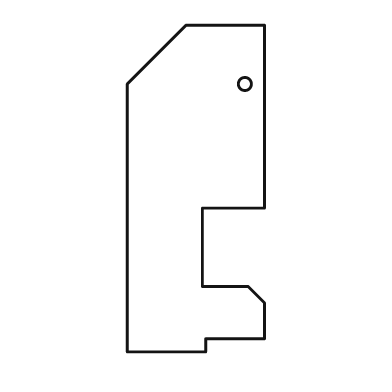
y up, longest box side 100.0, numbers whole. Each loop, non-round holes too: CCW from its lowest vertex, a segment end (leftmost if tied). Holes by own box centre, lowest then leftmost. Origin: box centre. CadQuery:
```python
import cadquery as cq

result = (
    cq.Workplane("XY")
    .moveTo(-21.0, -50.0)
    .lineTo(3.0, -50.0)
    .lineTo(3.0, -46.0)
    .lineTo(21.0, -46.0)
    .lineTo(21.0, -35.0)
    .lineTo(16.0, -30.0)
    .lineTo(2.0, -30.0)
    .lineTo(2.0, -6.0)
    .lineTo(21.0, -6.0)
    .lineTo(21.0, 50.0)
    .lineTo(-3.0, 50.0)
    .lineTo(-21.0, 32.0)
    .close()
    .moveTo(15.0, 32.0)
    .circle(2.0)
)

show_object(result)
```